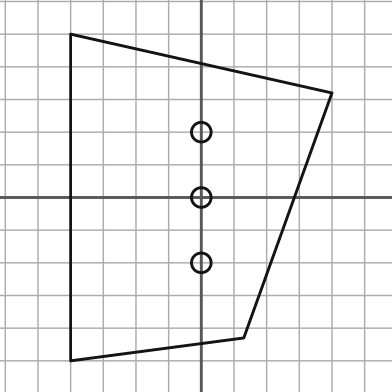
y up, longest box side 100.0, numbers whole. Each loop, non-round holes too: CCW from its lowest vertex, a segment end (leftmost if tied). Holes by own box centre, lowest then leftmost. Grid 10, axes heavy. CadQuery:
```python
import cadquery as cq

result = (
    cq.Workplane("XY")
    .moveTo(-40.0, -50.0)
    .lineTo(13.0, -43.0)
    .lineTo(40.0, 32.0)
    .lineTo(-40.0, 50.0)
    .close()
    .moveTo(0.0, -20.0)
    .circle(3.0)
    .moveTo(0.0, 0.0)
    .circle(3.0)
    .moveTo(0.0, 20.0)
    .circle(3.0)
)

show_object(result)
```